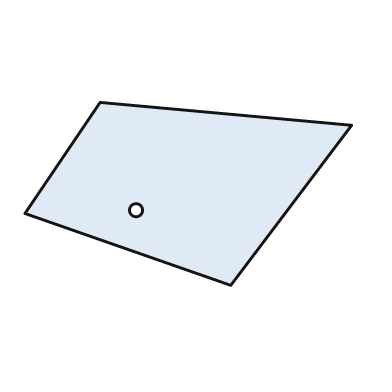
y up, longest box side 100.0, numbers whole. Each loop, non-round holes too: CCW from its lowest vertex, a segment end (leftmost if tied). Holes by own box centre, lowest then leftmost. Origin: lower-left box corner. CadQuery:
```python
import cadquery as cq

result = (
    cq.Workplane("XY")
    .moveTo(63.0, 0.0)
    .lineTo(100.0, 49.0)
    .lineTo(23.0, 56.0)
    .lineTo(0.0, 22.0)
    .close()
    .moveTo(34.0, 23.0)
    .circle(2.0)
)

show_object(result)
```